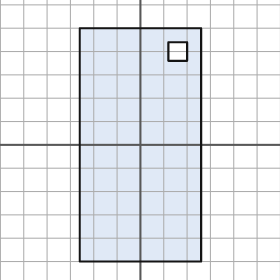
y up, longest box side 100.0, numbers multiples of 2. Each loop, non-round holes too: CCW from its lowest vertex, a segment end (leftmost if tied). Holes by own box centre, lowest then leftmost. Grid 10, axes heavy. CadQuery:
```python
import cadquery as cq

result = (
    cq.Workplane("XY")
    .moveTo(-26.0, -50.0)
    .lineTo(26.0, -50.0)
    .lineTo(26.0, 50.0)
    .lineTo(-26.0, 50.0)
    .close()
    .moveTo(12.0, 36.0)
    .lineTo(20.0, 36.0)
    .lineTo(20.0, 44.0)
    .lineTo(12.0, 44.0)
    .close()
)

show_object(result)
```